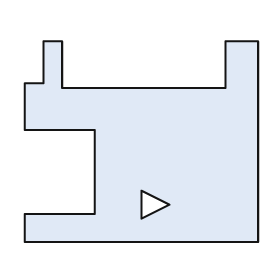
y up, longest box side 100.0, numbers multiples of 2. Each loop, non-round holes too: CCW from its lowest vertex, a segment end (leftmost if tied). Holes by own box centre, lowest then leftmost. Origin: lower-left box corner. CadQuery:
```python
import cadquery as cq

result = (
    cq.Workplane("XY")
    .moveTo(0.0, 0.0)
    .lineTo(100.0, 0.0)
    .lineTo(100.0, 86.0)
    .lineTo(86.0, 86.0)
    .lineTo(86.0, 66.0)
    .lineTo(16.0, 66.0)
    .lineTo(16.0, 86.0)
    .lineTo(8.0, 86.0)
    .lineTo(8.0, 68.0)
    .lineTo(0.0, 68.0)
    .lineTo(0.0, 48.0)
    .lineTo(30.0, 48.0)
    .lineTo(30.0, 12.0)
    .lineTo(0.0, 12.0)
    .close()
    .moveTo(50.0, 10.0)
    .lineTo(62.0, 16.0)
    .lineTo(50.0, 22.0)
    .close()
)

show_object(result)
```